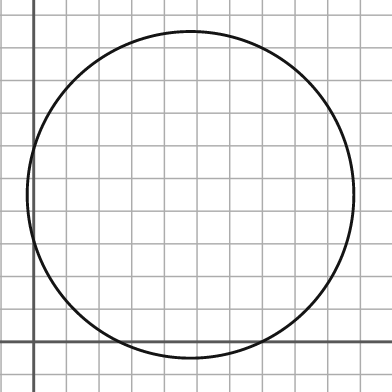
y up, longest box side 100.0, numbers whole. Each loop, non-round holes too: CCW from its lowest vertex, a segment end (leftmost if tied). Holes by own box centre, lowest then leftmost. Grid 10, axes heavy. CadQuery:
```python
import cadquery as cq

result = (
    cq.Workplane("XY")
    .moveTo(48.0, 45.0)
    .circle(50.0)
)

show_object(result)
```